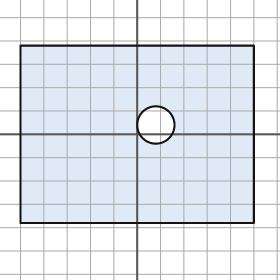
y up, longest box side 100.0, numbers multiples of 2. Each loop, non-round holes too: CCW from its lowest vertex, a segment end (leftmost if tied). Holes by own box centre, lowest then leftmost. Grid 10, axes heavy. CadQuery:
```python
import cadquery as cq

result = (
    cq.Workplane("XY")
    .moveTo(-50.0, -38.0)
    .lineTo(50.0, -38.0)
    .lineTo(50.0, 38.0)
    .lineTo(-50.0, 38.0)
    .close()
    .moveTo(8.0, 4.0)
    .circle(8.0)
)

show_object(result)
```